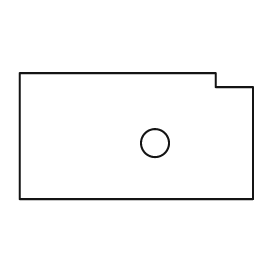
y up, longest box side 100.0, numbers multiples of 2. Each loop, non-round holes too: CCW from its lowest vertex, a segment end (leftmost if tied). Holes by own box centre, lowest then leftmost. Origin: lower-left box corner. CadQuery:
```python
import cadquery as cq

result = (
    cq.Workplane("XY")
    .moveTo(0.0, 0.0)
    .lineTo(100.0, 0.0)
    .lineTo(100.0, 48.0)
    .lineTo(84.0, 48.0)
    .lineTo(84.0, 54.0)
    .lineTo(0.0, 54.0)
    .close()
    .moveTo(58.0, 24.0)
    .circle(6.0)
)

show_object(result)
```